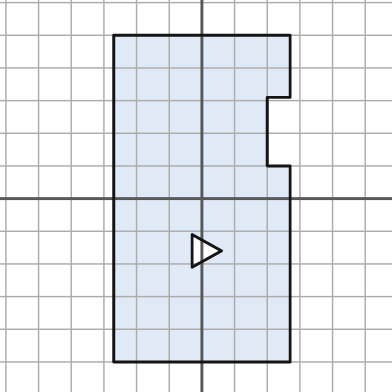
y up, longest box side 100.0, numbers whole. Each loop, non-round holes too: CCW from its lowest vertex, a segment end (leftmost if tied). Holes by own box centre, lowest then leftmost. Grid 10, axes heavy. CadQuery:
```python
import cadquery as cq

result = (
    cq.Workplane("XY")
    .moveTo(-27.0, -50.0)
    .lineTo(27.0, -50.0)
    .lineTo(27.0, 10.0)
    .lineTo(20.0, 10.0)
    .lineTo(20.0, 31.0)
    .lineTo(27.0, 31.0)
    .lineTo(27.0, 50.0)
    .lineTo(-27.0, 50.0)
    .close()
    .moveTo(-3.0, -21.0)
    .lineTo(6.0, -16.0)
    .lineTo(-3.0, -11.0)
    .close()
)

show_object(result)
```